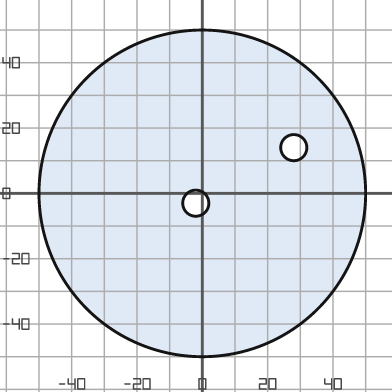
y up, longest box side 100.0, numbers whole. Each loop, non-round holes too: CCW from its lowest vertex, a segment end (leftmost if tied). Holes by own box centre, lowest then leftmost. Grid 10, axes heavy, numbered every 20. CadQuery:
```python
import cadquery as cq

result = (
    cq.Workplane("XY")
    .moveTo(0.0, 0.0)
    .circle(50.0)
    .moveTo(-2.0, -3.0)
    .circle(4.0)
    .moveTo(28.0, 14.0)
    .circle(4.0)
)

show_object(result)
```